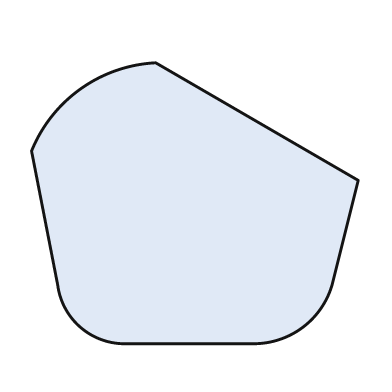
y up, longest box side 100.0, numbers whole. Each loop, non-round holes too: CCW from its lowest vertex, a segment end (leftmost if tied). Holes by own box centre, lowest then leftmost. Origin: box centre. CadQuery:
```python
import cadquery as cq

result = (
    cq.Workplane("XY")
    .moveTo(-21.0, -43.0)
    .lineTo(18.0, -43.0)
    .threePointArc((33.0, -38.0), (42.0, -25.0))
    .lineTo(50.0, 7.0)
    .lineTo(-12.0, 43.0)
    .threePointArc((-35.0, 35.0), (-50.0, 16.0))
    .lineTo(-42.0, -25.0)
    .threePointArc((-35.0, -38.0), (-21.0, -43.0))
    .close()
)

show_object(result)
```